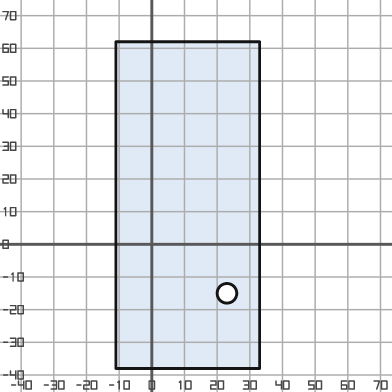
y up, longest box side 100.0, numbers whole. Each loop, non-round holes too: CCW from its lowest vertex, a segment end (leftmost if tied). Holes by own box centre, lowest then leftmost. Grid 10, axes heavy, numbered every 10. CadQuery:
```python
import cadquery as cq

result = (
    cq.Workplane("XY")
    .moveTo(-11.0, -38.0)
    .lineTo(33.0, -38.0)
    .lineTo(33.0, 62.0)
    .lineTo(-11.0, 62.0)
    .close()
    .moveTo(23.0, -15.0)
    .circle(3.0)
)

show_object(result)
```